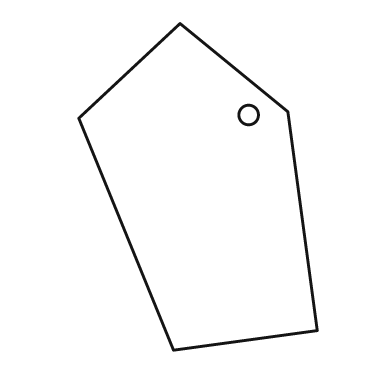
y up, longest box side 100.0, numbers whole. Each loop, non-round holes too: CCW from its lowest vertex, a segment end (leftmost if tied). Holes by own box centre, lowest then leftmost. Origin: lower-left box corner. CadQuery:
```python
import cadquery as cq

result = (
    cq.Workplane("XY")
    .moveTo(29.0, 0.0)
    .lineTo(73.0, 6.0)
    .lineTo(64.0, 73.0)
    .lineTo(31.0, 100.0)
    .lineTo(0.0, 71.0)
    .close()
    .moveTo(52.0, 72.0)
    .circle(3.0)
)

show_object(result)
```